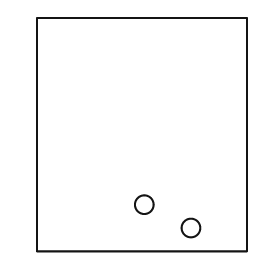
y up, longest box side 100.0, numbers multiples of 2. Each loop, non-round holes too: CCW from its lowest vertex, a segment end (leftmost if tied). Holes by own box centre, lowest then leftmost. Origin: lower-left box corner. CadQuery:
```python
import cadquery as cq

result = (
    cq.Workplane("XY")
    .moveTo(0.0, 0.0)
    .lineTo(90.0, 0.0)
    .lineTo(90.0, 100.0)
    .lineTo(0.0, 100.0)
    .close()
    .moveTo(66.0, 10.0)
    .circle(4.0)
    .moveTo(46.0, 20.0)
    .circle(4.0)
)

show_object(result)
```